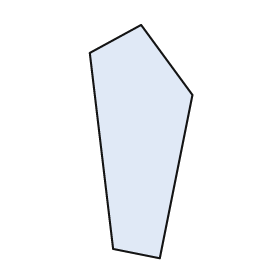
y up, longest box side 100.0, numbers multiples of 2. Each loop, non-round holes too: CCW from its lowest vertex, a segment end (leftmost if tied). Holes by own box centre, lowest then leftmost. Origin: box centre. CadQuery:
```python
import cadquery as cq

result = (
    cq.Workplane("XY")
    .moveTo(8.0, -50.0)
    .lineTo(22.0, 20.0)
    .lineTo(0.0, 50.0)
    .lineTo(-22.0, 38.0)
    .lineTo(-12.0, -46.0)
    .close()
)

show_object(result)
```